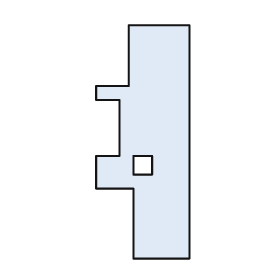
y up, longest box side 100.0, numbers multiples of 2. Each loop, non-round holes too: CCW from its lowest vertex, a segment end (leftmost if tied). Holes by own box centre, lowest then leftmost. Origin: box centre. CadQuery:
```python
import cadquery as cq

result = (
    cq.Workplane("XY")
    .moveTo(-4.0, -50.0)
    .lineTo(20.0, -50.0)
    .lineTo(20.0, 50.0)
    .lineTo(-6.0, 50.0)
    .lineTo(-6.0, 24.0)
    .lineTo(-20.0, 24.0)
    .lineTo(-20.0, 18.0)
    .lineTo(-10.0, 18.0)
    .lineTo(-10.0, -6.0)
    .lineTo(-20.0, -6.0)
    .lineTo(-20.0, -20.0)
    .lineTo(-4.0, -20.0)
    .close()
    .moveTo(-4.0, -14.0)
    .lineTo(4.0, -14.0)
    .lineTo(4.0, -6.0)
    .lineTo(-4.0, -6.0)
    .close()
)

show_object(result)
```